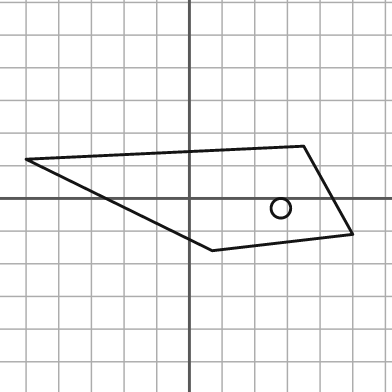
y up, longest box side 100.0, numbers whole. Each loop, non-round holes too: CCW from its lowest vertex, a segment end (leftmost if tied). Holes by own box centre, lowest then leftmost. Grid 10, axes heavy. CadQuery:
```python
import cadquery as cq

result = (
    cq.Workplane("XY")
    .moveTo(7.0, -16.0)
    .lineTo(50.0, -11.0)
    .lineTo(35.0, 16.0)
    .lineTo(-50.0, 12.0)
    .close()
    .moveTo(28.0, -3.0)
    .circle(3.0)
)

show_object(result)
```